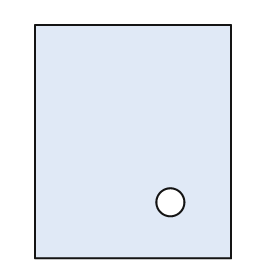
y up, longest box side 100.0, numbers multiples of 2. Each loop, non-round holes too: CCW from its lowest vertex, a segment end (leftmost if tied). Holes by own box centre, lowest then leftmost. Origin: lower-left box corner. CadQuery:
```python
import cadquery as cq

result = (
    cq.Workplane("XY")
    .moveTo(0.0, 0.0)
    .lineTo(84.0, 0.0)
    .lineTo(84.0, 100.0)
    .lineTo(0.0, 100.0)
    .close()
    .moveTo(58.0, 24.0)
    .circle(6.0)
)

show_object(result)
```